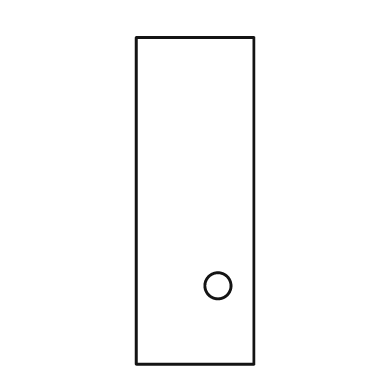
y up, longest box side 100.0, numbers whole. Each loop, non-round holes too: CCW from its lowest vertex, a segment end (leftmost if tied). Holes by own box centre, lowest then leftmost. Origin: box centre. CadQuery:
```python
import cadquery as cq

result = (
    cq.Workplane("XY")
    .moveTo(-18.0, -50.0)
    .lineTo(18.0, -50.0)
    .lineTo(18.0, 50.0)
    .lineTo(-18.0, 50.0)
    .close()
    .moveTo(7.0, -26.0)
    .circle(4.0)
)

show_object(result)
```